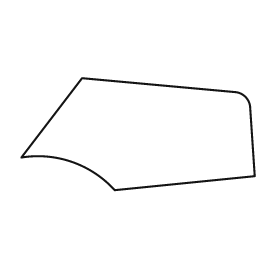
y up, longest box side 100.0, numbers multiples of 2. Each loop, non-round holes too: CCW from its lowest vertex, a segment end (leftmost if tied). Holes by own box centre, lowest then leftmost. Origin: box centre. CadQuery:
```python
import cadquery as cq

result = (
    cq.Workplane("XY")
    .moveTo(-10.0, -24.0)
    .lineTo(50.0, -18.0)
    .lineTo(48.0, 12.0)
    .threePointArc((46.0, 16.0), (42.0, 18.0))
    .lineTo(-24.0, 24.0)
    .lineTo(-50.0, -10.0)
    .threePointArc((-28.0, -12.0), (-10.0, -24.0))
    .close()
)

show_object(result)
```